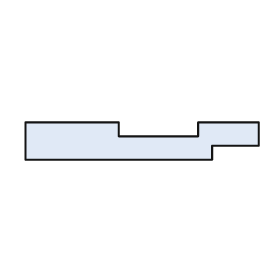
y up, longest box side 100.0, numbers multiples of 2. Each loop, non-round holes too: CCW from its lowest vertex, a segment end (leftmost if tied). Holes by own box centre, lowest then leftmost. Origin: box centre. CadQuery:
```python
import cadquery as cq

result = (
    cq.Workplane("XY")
    .moveTo(-50.0, -8.0)
    .lineTo(30.0, -8.0)
    .lineTo(30.0, -2.0)
    .lineTo(50.0, -2.0)
    .lineTo(50.0, 8.0)
    .lineTo(24.0, 8.0)
    .lineTo(24.0, 2.0)
    .lineTo(-10.0, 2.0)
    .lineTo(-10.0, 8.0)
    .lineTo(-50.0, 8.0)
    .close()
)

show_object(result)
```